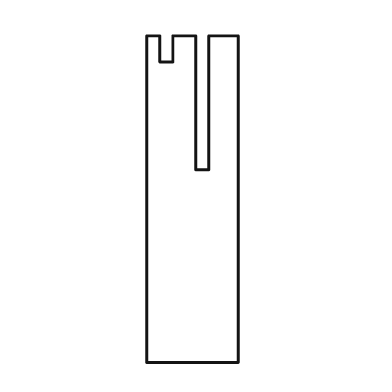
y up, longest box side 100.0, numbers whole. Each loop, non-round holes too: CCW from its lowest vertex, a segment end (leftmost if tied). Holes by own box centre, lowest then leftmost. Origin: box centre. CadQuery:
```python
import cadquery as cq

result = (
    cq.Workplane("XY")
    .moveTo(-14.0, -50.0)
    .lineTo(14.0, -50.0)
    .lineTo(14.0, 50.0)
    .lineTo(5.0, 50.0)
    .lineTo(5.0, 9.0)
    .lineTo(1.0, 9.0)
    .lineTo(1.0, 50.0)
    .lineTo(-6.0, 50.0)
    .lineTo(-6.0, 42.0)
    .lineTo(-10.0, 42.0)
    .lineTo(-10.0, 50.0)
    .lineTo(-14.0, 50.0)
    .close()
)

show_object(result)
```